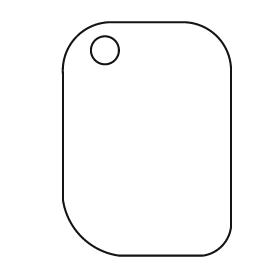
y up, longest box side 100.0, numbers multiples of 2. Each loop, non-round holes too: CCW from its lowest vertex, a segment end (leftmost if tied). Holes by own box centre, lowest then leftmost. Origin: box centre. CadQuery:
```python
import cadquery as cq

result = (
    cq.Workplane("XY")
    .moveTo(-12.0, -50.0)
    .lineTo(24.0, -50.0)
    .threePointArc((32.0, -46.0), (36.0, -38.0))
    .lineTo(36.0, 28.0)
    .threePointArc((30.0, 44.0), (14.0, 50.0))
    .lineTo(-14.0, 50.0)
    .threePointArc((-30.0, 44.0), (-36.0, 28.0))
    .lineTo(-36.0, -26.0)
    .threePointArc((-28.0, -42.0), (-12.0, -50.0))
    .close()
    .moveTo(-18.0, 38.0)
    .circle(6.0)
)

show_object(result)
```